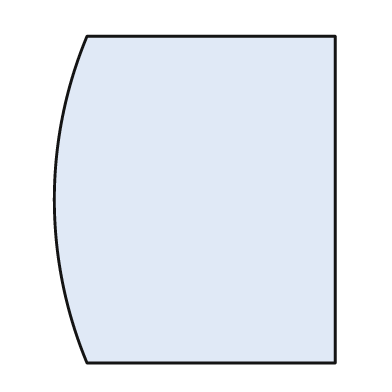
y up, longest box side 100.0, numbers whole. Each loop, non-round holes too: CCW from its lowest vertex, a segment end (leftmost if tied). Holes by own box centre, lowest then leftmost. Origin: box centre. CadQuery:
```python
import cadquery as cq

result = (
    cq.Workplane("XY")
    .moveTo(-33.0, -50.0)
    .lineTo(43.0, -50.0)
    .lineTo(43.0, 50.0)
    .lineTo(-33.0, 50.0)
    .threePointArc((-43.0, 0.0), (-33.0, -50.0))
    .close()
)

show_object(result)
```